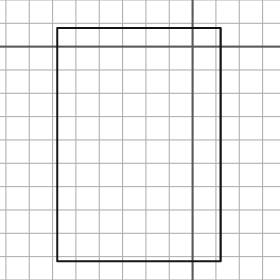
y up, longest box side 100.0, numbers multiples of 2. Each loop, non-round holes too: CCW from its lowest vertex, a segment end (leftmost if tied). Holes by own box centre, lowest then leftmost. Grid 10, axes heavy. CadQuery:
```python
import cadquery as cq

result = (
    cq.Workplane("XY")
    .moveTo(-58.0, -92.0)
    .lineTo(12.0, -92.0)
    .lineTo(12.0, 8.0)
    .lineTo(-58.0, 8.0)
    .close()
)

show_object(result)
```